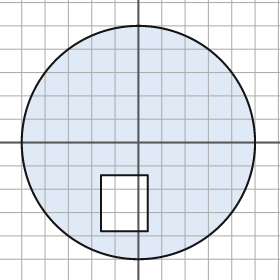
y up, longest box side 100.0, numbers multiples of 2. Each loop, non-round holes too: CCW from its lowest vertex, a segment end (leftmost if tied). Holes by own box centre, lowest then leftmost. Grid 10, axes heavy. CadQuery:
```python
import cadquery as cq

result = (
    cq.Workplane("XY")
    .moveTo(0.0, 0.0)
    .circle(50.0)
    .moveTo(-16.0, -38.0)
    .lineTo(4.0, -38.0)
    .lineTo(4.0, -14.0)
    .lineTo(-16.0, -14.0)
    .close()
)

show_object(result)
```